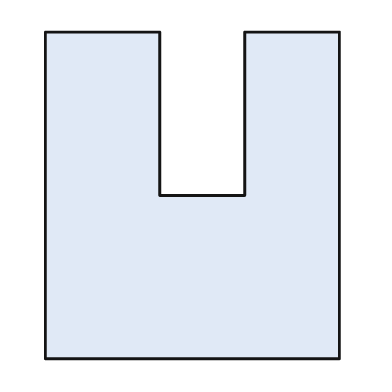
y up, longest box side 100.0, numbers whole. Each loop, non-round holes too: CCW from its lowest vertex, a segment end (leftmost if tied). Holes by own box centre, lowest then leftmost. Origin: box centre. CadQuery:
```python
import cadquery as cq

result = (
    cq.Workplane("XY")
    .moveTo(-45.0, -50.0)
    .lineTo(45.0, -50.0)
    .lineTo(45.0, 50.0)
    .lineTo(16.0, 50.0)
    .lineTo(16.0, 0.0)
    .lineTo(-10.0, 0.0)
    .lineTo(-10.0, 50.0)
    .lineTo(-45.0, 50.0)
    .close()
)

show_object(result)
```